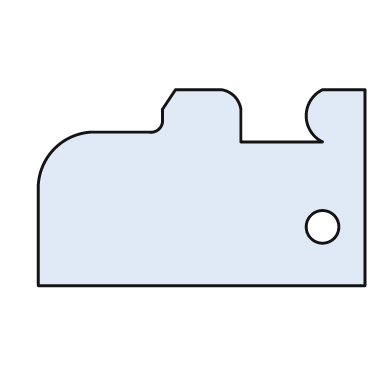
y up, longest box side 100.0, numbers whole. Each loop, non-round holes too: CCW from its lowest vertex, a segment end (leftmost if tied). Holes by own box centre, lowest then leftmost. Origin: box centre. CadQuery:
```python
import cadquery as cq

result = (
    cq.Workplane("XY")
    .moveTo(-50.0, -30.0)
    .lineTo(50.0, -30.0)
    .lineTo(50.0, 30.0)
    .lineTo(37.0, 30.0)
    .threePointArc((32.0, 22.0), (37.0, 14.0))
    .lineTo(12.0, 14.0)
    .lineTo(12.0, 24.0)
    .threePointArc((10.0, 28.0), (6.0, 30.0))
    .lineTo(-8.0, 30.0)
    .lineTo(-12.0, 24.0)
    .lineTo(-12.0, 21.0)
    .threePointArc((-13.0, 18.0), (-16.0, 17.0))
    .lineTo(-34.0, 17.0)
    .threePointArc((-45.0, 12.0), (-50.0, 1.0))
    .close()
    .moveTo(37.0, -12.0)
    .circle(5.0)
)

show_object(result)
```